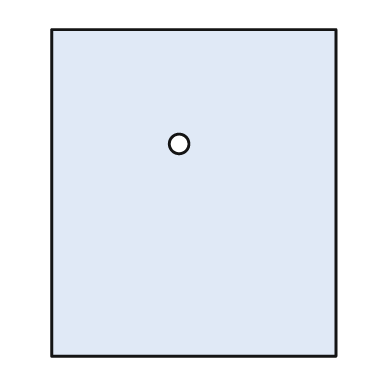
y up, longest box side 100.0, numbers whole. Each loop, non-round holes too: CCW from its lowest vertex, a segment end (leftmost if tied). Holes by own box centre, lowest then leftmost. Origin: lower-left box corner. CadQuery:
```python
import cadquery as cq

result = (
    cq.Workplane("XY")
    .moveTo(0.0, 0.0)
    .lineTo(87.0, 0.0)
    .lineTo(87.0, 100.0)
    .lineTo(0.0, 100.0)
    .close()
    .moveTo(39.0, 65.0)
    .circle(3.0)
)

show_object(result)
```